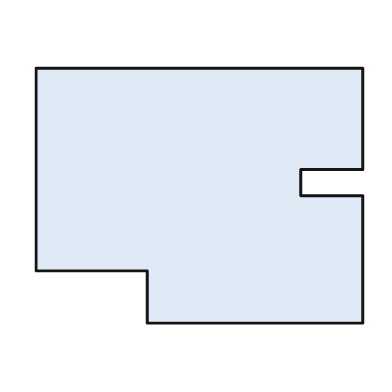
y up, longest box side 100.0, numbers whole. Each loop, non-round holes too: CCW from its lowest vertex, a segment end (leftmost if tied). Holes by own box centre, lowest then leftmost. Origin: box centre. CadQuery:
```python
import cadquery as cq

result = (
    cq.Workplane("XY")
    .moveTo(-16.0, -39.0)
    .lineTo(50.0, -39.0)
    .lineTo(50.0, 0.0)
    .lineTo(31.0, 0.0)
    .lineTo(31.0, 8.0)
    .lineTo(50.0, 8.0)
    .lineTo(50.0, 39.0)
    .lineTo(-50.0, 39.0)
    .lineTo(-50.0, -23.0)
    .lineTo(-16.0, -23.0)
    .close()
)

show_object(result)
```